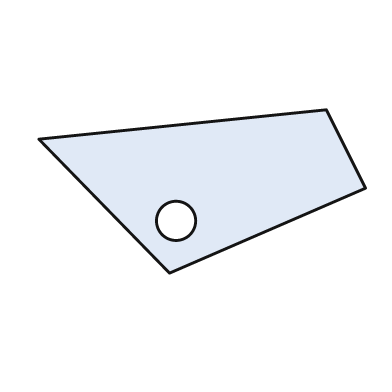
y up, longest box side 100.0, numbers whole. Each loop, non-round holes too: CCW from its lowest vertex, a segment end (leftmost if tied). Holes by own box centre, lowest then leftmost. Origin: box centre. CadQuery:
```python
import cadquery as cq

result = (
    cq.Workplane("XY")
    .moveTo(-10.0, -25.0)
    .lineTo(50.0, 1.0)
    .lineTo(38.0, 25.0)
    .lineTo(-50.0, 16.0)
    .close()
    .moveTo(-8.0, -9.0)
    .circle(6.0)
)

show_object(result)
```